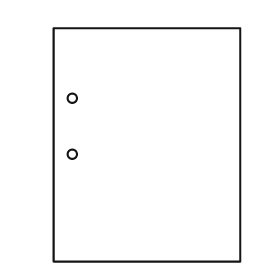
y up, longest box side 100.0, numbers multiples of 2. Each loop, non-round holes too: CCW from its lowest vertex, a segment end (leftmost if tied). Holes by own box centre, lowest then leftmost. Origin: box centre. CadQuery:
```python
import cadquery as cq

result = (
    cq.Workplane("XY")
    .moveTo(-40.0, -50.0)
    .lineTo(40.0, -50.0)
    .lineTo(40.0, 50.0)
    .lineTo(-40.0, 50.0)
    .close()
    .moveTo(-32.0, -4.0)
    .circle(2.0)
    .moveTo(-32.0, 20.0)
    .circle(2.0)
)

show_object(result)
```